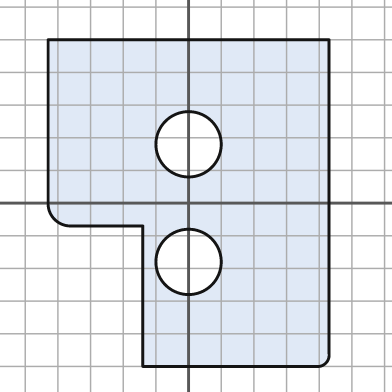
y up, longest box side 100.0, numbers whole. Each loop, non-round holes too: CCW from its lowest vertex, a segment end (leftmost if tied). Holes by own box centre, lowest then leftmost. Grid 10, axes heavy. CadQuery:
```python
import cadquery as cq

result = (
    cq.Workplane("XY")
    .moveTo(-14.0, -50.0)
    .lineTo(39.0, -50.0)
    .threePointArc((42.0, -49.0), (43.0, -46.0))
    .lineTo(43.0, 50.0)
    .lineTo(-43.0, 50.0)
    .lineTo(-43.0, 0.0)
    .threePointArc((-41.0, -5.0), (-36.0, -7.0))
    .lineTo(-14.0, -7.0)
    .close()
    .moveTo(0.0, -18.0)
    .circle(10.0)
    .moveTo(0.0, 18.0)
    .circle(10.0)
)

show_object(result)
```